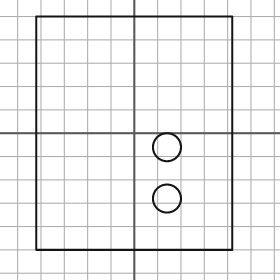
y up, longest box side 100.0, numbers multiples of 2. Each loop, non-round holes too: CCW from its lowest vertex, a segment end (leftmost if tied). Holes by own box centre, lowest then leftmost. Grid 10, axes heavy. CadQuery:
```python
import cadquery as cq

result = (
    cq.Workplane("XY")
    .moveTo(-42.0, -50.0)
    .lineTo(42.0, -50.0)
    .lineTo(42.0, 50.0)
    .lineTo(-42.0, 50.0)
    .close()
    .moveTo(14.0, -28.0)
    .circle(6.0)
    .moveTo(14.0, -6.0)
    .circle(6.0)
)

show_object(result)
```